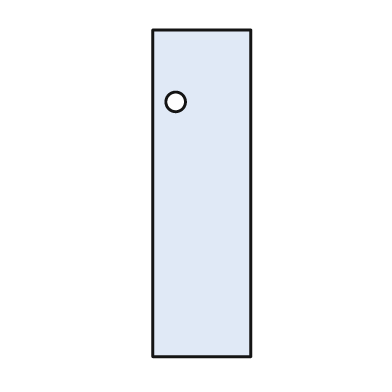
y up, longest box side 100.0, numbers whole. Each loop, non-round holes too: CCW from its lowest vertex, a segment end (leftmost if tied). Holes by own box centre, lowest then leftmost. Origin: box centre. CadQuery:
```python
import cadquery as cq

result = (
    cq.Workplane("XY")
    .moveTo(-15.0, -50.0)
    .lineTo(15.0, -50.0)
    .lineTo(15.0, 50.0)
    .lineTo(-15.0, 50.0)
    .close()
    .moveTo(-8.0, 28.0)
    .circle(3.0)
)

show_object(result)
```